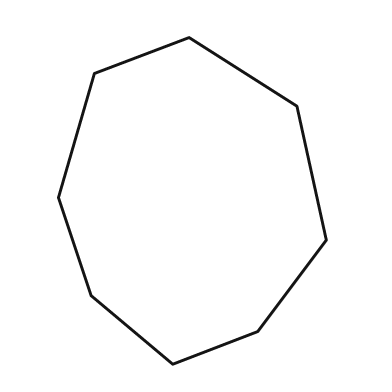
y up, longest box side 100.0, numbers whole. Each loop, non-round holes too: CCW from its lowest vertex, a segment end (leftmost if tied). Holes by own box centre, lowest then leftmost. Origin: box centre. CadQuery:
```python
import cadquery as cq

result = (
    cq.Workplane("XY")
    .moveTo(-6.0, -50.0)
    .lineTo(20.0, -40.0)
    .lineTo(41.0, -12.0)
    .lineTo(32.0, 29.0)
    .lineTo(-1.0, 50.0)
    .lineTo(-30.0, 39.0)
    .lineTo(-41.0, 1.0)
    .lineTo(-31.0, -29.0)
    .close()
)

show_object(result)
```